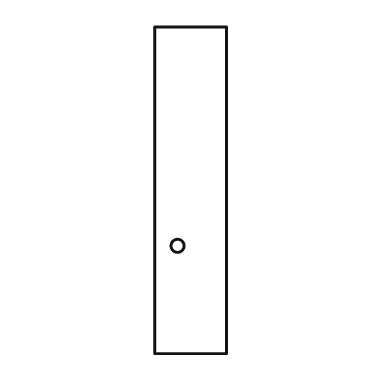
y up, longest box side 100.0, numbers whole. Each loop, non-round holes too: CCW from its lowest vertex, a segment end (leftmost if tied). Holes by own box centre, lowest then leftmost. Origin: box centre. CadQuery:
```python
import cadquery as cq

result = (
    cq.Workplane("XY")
    .moveTo(-11.0, -50.0)
    .lineTo(11.0, -50.0)
    .lineTo(11.0, 50.0)
    .lineTo(-11.0, 50.0)
    .close()
    .moveTo(-4.0, -17.0)
    .circle(2.0)
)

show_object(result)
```